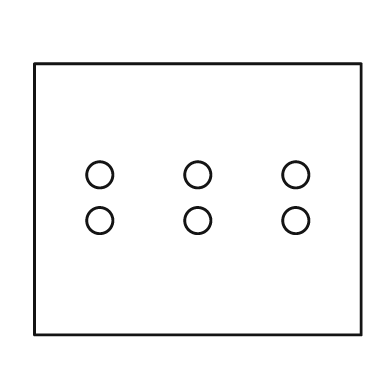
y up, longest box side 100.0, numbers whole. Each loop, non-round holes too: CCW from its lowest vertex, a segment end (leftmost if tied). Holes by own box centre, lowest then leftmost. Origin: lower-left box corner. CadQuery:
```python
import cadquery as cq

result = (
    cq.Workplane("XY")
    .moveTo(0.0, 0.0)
    .lineTo(100.0, 0.0)
    .lineTo(100.0, 83.0)
    .lineTo(0.0, 83.0)
    .close()
    .moveTo(20.0, 35.0)
    .circle(4.0)
    .moveTo(50.0, 35.0)
    .circle(4.0)
    .moveTo(80.0, 35.0)
    .circle(4.0)
    .moveTo(20.0, 49.0)
    .circle(4.0)
    .moveTo(50.0, 49.0)
    .circle(4.0)
    .moveTo(80.0, 49.0)
    .circle(4.0)
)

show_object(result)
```